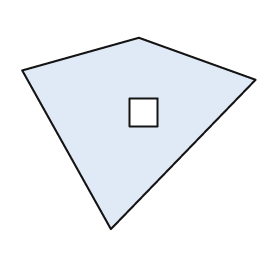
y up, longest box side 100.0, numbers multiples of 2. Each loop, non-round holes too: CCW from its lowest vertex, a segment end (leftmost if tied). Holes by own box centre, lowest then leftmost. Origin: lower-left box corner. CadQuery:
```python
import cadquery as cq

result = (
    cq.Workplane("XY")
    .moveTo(38.0, 0.0)
    .lineTo(100.0, 64.0)
    .lineTo(50.0, 82.0)
    .lineTo(0.0, 68.0)
    .close()
    .moveTo(46.0, 44.0)
    .lineTo(58.0, 44.0)
    .lineTo(58.0, 56.0)
    .lineTo(46.0, 56.0)
    .close()
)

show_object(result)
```